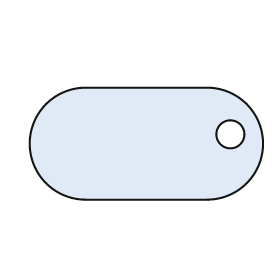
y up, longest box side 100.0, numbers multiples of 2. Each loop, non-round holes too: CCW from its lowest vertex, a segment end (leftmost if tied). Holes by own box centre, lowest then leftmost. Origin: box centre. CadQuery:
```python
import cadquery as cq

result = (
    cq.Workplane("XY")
    .moveTo(-26.0, -24.0)
    .lineTo(26.0, -24.0)
    .threePointArc((50.0, 0.0), (26.0, 24.0))
    .lineTo(-26.0, 24.0)
    .threePointArc((-50.0, 0.0), (-26.0, -24.0))
    .close()
    .moveTo(36.0, 4.0)
    .circle(6.0)
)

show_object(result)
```